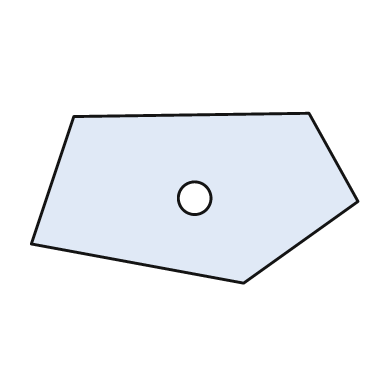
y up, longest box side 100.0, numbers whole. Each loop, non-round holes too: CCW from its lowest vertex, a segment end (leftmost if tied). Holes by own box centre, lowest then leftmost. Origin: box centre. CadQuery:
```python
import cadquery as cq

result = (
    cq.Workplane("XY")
    .moveTo(15.0, -26.0)
    .lineTo(50.0, -1.0)
    .lineTo(35.0, 26.0)
    .lineTo(-37.0, 25.0)
    .lineTo(-50.0, -14.0)
    .close()
    .moveTo(0.0, 0.0)
    .circle(5.0)
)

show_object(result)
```